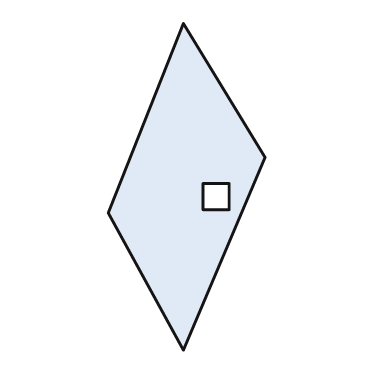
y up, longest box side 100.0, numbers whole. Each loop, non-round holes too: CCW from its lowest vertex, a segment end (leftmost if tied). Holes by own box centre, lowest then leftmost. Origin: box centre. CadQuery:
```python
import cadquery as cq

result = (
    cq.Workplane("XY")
    .moveTo(-1.0, -50.0)
    .lineTo(24.0, 9.0)
    .lineTo(-1.0, 50.0)
    .lineTo(-24.0, -8.0)
    .close()
    .moveTo(5.0, -7.0)
    .lineTo(13.0, -7.0)
    .lineTo(13.0, 1.0)
    .lineTo(5.0, 1.0)
    .close()
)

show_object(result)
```